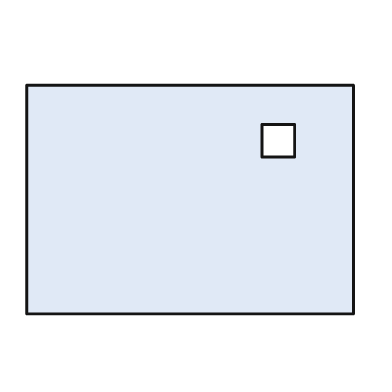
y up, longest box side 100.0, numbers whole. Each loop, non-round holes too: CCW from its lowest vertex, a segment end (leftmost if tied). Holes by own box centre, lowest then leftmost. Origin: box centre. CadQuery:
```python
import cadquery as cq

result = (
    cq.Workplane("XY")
    .moveTo(-50.0, -35.0)
    .lineTo(50.0, -35.0)
    .lineTo(50.0, 35.0)
    .lineTo(-50.0, 35.0)
    .close()
    .moveTo(22.0, 13.0)
    .lineTo(32.0, 13.0)
    .lineTo(32.0, 23.0)
    .lineTo(22.0, 23.0)
    .close()
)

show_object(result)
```